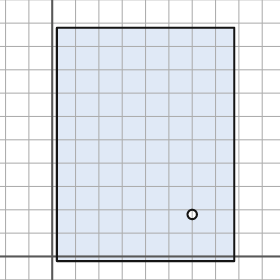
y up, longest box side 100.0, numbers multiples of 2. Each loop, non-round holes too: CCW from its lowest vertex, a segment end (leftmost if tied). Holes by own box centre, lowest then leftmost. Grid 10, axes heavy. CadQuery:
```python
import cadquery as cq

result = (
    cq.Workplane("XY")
    .moveTo(2.0, -2.0)
    .lineTo(78.0, -2.0)
    .lineTo(78.0, 98.0)
    .lineTo(2.0, 98.0)
    .close()
    .moveTo(60.0, 18.0)
    .circle(2.0)
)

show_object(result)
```